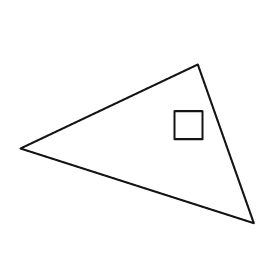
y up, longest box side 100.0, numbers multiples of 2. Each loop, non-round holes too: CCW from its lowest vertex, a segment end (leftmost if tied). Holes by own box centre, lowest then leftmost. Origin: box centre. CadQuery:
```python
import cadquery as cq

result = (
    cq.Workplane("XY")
    .moveTo(50.0, -34.0)
    .lineTo(26.0, 34.0)
    .lineTo(-50.0, -2.0)
    .close()
    .moveTo(16.0, 2.0)
    .lineTo(28.0, 2.0)
    .lineTo(28.0, 14.0)
    .lineTo(16.0, 14.0)
    .close()
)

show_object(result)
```